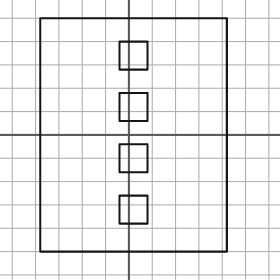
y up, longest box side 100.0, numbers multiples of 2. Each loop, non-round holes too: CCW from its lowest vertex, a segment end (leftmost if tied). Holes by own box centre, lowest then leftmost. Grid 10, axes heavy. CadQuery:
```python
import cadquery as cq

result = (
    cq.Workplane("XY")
    .moveTo(-38.0, -50.0)
    .lineTo(42.0, -50.0)
    .lineTo(42.0, 50.0)
    .lineTo(-38.0, 50.0)
    .close()
    .moveTo(-4.0, -38.0)
    .lineTo(8.0, -38.0)
    .lineTo(8.0, -26.0)
    .lineTo(-4.0, -26.0)
    .close()
    .moveTo(-4.0, -16.0)
    .lineTo(8.0, -16.0)
    .lineTo(8.0, -4.0)
    .lineTo(-4.0, -4.0)
    .close()
    .moveTo(-4.0, 6.0)
    .lineTo(8.0, 6.0)
    .lineTo(8.0, 18.0)
    .lineTo(-4.0, 18.0)
    .close()
    .moveTo(-4.0, 28.0)
    .lineTo(8.0, 28.0)
    .lineTo(8.0, 40.0)
    .lineTo(-4.0, 40.0)
    .close()
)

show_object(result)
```